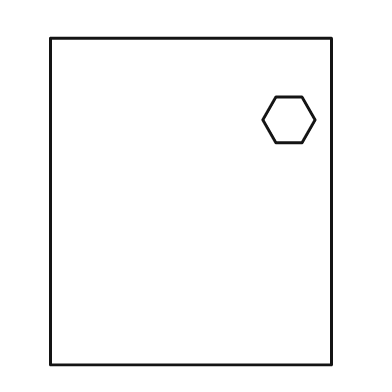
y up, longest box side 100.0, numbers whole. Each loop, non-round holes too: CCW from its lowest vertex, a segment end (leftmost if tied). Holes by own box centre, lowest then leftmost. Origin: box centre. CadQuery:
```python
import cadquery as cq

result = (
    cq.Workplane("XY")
    .moveTo(-43.0, -50.0)
    .lineTo(43.0, -50.0)
    .lineTo(43.0, 50.0)
    .lineTo(-43.0, 50.0)
    .close()
    .moveTo(26.0, 18.0)
    .lineTo(34.0, 18.0)
    .lineTo(38.0, 25.0)
    .lineTo(34.0, 32.0)
    .lineTo(26.0, 32.0)
    .lineTo(22.0, 25.0)
    .close()
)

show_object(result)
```